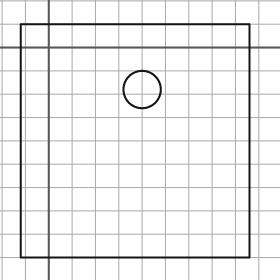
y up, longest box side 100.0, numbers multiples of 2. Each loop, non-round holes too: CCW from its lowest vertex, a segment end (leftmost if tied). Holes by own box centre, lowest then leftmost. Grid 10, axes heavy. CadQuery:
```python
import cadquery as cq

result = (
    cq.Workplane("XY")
    .moveTo(-12.0, -90.0)
    .lineTo(86.0, -90.0)
    .lineTo(86.0, 10.0)
    .lineTo(-12.0, 10.0)
    .close()
    .moveTo(40.0, -18.0)
    .circle(8.0)
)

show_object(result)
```